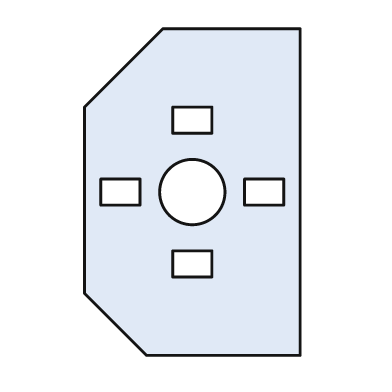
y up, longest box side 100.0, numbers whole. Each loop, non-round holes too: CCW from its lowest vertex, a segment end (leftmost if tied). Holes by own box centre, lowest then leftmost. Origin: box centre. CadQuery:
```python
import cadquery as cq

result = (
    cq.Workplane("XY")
    .moveTo(-14.0, -50.0)
    .lineTo(33.0, -50.0)
    .lineTo(33.0, 50.0)
    .lineTo(-9.0, 50.0)
    .lineTo(-33.0, 26.0)
    .lineTo(-33.0, -31.0)
    .close()
    .moveTo(-6.0, -26.0)
    .lineTo(6.0, -26.0)
    .lineTo(6.0, -18.0)
    .lineTo(-6.0, -18.0)
    .close()
    .moveTo(-28.0, -4.0)
    .lineTo(-16.0, -4.0)
    .lineTo(-16.0, 4.0)
    .lineTo(-28.0, 4.0)
    .close()
    .moveTo(0.0, 0.0)
    .circle(10.0)
    .moveTo(16.0, -4.0)
    .lineTo(28.0, -4.0)
    .lineTo(28.0, 4.0)
    .lineTo(16.0, 4.0)
    .close()
    .moveTo(-6.0, 18.0)
    .lineTo(6.0, 18.0)
    .lineTo(6.0, 26.0)
    .lineTo(-6.0, 26.0)
    .close()
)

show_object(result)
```